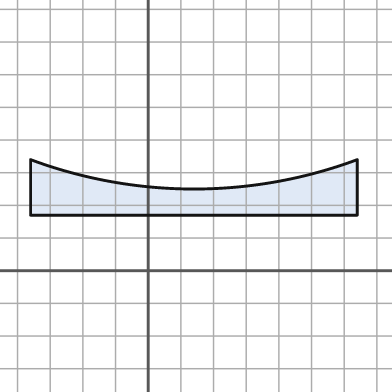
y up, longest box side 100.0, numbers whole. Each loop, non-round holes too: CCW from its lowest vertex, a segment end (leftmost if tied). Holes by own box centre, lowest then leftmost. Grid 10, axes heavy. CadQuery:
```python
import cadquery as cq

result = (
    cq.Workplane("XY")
    .moveTo(-36.0, 17.0)
    .lineTo(64.0, 17.0)
    .lineTo(64.0, 34.0)
    .threePointArc((14.0, 25.0), (-36.0, 34.0))
    .close()
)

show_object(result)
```